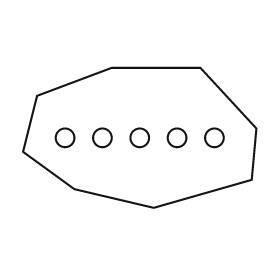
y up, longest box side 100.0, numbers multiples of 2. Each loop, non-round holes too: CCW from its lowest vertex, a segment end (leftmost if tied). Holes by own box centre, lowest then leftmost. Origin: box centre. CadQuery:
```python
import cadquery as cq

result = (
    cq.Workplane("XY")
    .moveTo(6.0, -30.0)
    .lineTo(48.0, -18.0)
    .lineTo(50.0, 4.0)
    .lineTo(26.0, 30.0)
    .lineTo(-12.0, 30.0)
    .lineTo(-44.0, 18.0)
    .lineTo(-50.0, -6.0)
    .lineTo(-28.0, -22.0)
    .close()
    .moveTo(-32.0, 0.0)
    .circle(4.0)
    .moveTo(-16.0, 0.0)
    .circle(4.0)
    .moveTo(0.0, 0.0)
    .circle(4.0)
    .moveTo(16.0, 0.0)
    .circle(4.0)
    .moveTo(32.0, 0.0)
    .circle(4.0)
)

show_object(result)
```